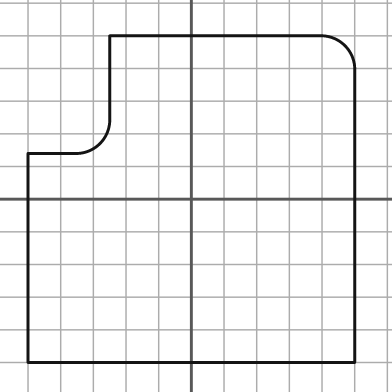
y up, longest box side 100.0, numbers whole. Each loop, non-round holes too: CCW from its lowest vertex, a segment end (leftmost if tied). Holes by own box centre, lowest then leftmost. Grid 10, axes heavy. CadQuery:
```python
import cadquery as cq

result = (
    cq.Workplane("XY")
    .moveTo(-50.0, -50.0)
    .lineTo(50.0, -50.0)
    .lineTo(50.0, 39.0)
    .threePointArc((47.0, 47.0), (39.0, 50.0))
    .lineTo(-25.0, 50.0)
    .lineTo(-25.0, 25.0)
    .threePointArc((-28.0, 17.0), (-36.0, 14.0))
    .lineTo(-50.0, 14.0)
    .close()
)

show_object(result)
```